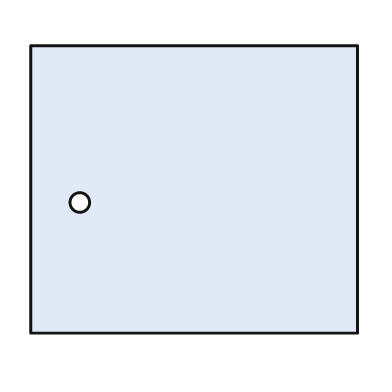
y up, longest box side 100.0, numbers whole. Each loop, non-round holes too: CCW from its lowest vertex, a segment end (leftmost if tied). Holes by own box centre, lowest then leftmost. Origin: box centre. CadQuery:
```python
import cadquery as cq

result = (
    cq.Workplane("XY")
    .moveTo(-50.0, -44.0)
    .lineTo(50.0, -44.0)
    .lineTo(50.0, 44.0)
    .lineTo(-50.0, 44.0)
    .close()
    .moveTo(-35.0, -4.0)
    .circle(3.0)
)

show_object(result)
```